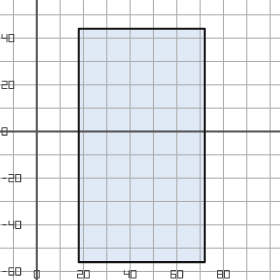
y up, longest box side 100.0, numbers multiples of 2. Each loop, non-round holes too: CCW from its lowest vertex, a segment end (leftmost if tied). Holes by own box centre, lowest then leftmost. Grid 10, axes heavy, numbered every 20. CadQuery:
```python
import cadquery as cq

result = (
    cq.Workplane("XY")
    .moveTo(18.0, -56.0)
    .lineTo(72.0, -56.0)
    .lineTo(72.0, 44.0)
    .lineTo(18.0, 44.0)
    .close()
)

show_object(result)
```